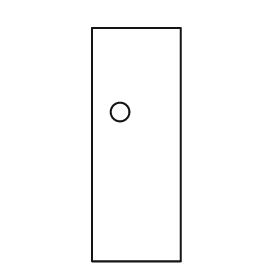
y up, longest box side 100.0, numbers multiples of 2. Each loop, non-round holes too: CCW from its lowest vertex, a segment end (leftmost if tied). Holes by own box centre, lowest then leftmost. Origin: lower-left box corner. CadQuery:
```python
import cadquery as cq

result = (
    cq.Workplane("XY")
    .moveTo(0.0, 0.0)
    .lineTo(38.0, 0.0)
    .lineTo(38.0, 100.0)
    .lineTo(0.0, 100.0)
    .close()
    .moveTo(12.0, 64.0)
    .circle(4.0)
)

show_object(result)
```